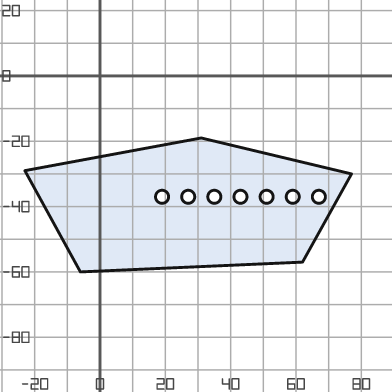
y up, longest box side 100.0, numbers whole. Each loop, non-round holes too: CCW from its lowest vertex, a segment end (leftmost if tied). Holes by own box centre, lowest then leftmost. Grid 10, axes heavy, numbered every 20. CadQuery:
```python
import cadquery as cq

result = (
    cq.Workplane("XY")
    .moveTo(-6.0, -60.0)
    .lineTo(62.0, -57.0)
    .lineTo(77.0, -30.0)
    .lineTo(31.0, -19.0)
    .lineTo(-23.0, -29.0)
    .close()
    .moveTo(19.0, -37.0)
    .circle(2.0)
    .moveTo(27.0, -37.0)
    .circle(2.0)
    .moveTo(35.0, -37.0)
    .circle(2.0)
    .moveTo(43.0, -37.0)
    .circle(2.0)
    .moveTo(51.0, -37.0)
    .circle(2.0)
    .moveTo(59.0, -37.0)
    .circle(2.0)
    .moveTo(67.0, -37.0)
    .circle(2.0)
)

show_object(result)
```